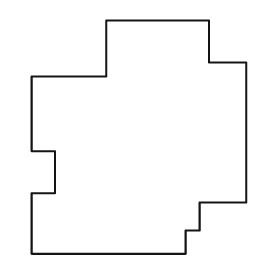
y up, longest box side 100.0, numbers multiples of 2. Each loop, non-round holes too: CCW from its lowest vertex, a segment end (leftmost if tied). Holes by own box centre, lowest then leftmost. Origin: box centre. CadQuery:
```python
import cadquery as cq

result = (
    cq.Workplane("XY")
    .moveTo(-46.0, -50.0)
    .lineTo(20.0, -50.0)
    .lineTo(20.0, -40.0)
    .lineTo(26.0, -40.0)
    .lineTo(26.0, -28.0)
    .lineTo(46.0, -28.0)
    .lineTo(46.0, 32.0)
    .lineTo(30.0, 32.0)
    .lineTo(30.0, 50.0)
    .lineTo(-14.0, 50.0)
    .lineTo(-14.0, 26.0)
    .lineTo(-46.0, 26.0)
    .lineTo(-46.0, -6.0)
    .lineTo(-36.0, -6.0)
    .lineTo(-36.0, -24.0)
    .lineTo(-46.0, -24.0)
    .close()
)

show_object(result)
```